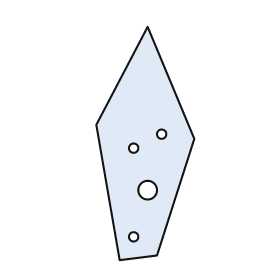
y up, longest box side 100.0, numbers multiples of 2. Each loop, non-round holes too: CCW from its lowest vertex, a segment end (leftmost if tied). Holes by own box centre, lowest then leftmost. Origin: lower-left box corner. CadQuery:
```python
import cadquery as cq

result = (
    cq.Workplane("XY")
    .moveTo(10.0, 0.0)
    .lineTo(26.0, 2.0)
    .lineTo(42.0, 52.0)
    .lineTo(22.0, 100.0)
    .lineTo(0.0, 58.0)
    .close()
    .moveTo(16.0, 10.0)
    .circle(2.0)
    .moveTo(22.0, 30.0)
    .circle(4.0)
    .moveTo(16.0, 48.0)
    .circle(2.0)
    .moveTo(28.0, 54.0)
    .circle(2.0)
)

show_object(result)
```